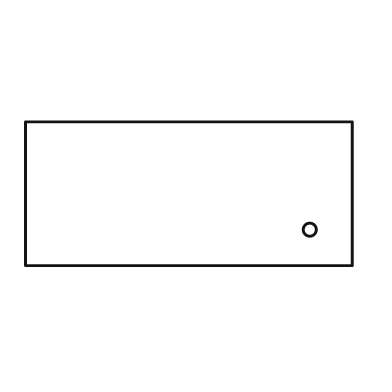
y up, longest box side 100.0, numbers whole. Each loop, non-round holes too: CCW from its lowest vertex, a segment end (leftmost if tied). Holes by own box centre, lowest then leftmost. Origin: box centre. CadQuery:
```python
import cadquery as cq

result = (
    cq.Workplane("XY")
    .moveTo(-50.0, -22.0)
    .lineTo(50.0, -22.0)
    .lineTo(50.0, 22.0)
    .lineTo(-50.0, 22.0)
    .close()
    .moveTo(37.0, -11.0)
    .circle(2.0)
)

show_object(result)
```